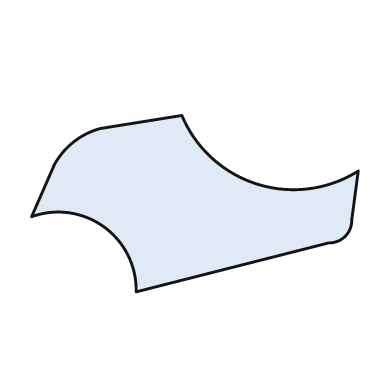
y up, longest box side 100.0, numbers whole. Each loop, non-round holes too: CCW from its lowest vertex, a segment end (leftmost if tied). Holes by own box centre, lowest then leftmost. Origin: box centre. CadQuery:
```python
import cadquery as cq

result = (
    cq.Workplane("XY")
    .moveTo(-18.0, -27.0)
    .lineTo(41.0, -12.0)
    .threePointArc((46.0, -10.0), (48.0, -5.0))
    .lineTo(50.0, 10.0)
    .threePointArc((19.0, 6.0), (-4.0, 27.0))
    .lineTo(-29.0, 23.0)
    .threePointArc((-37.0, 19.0), (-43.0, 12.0))
    .lineTo(-50.0, -4.0)
    .threePointArc((-28.0, -7.0), (-18.0, -27.0))
    .close()
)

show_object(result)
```